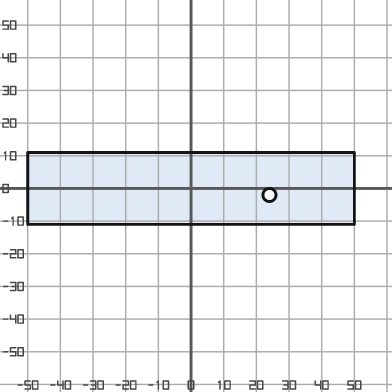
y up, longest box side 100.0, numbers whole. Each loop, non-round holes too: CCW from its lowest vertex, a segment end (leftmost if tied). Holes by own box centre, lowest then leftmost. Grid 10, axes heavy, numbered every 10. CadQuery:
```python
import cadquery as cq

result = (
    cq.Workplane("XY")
    .moveTo(-50.0, -11.0)
    .lineTo(50.0, -11.0)
    .lineTo(50.0, 11.0)
    .lineTo(-50.0, 11.0)
    .close()
    .moveTo(24.0, -2.0)
    .circle(2.0)
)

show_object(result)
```